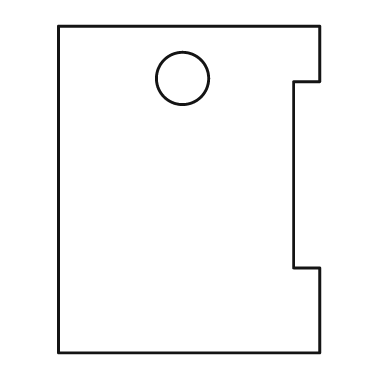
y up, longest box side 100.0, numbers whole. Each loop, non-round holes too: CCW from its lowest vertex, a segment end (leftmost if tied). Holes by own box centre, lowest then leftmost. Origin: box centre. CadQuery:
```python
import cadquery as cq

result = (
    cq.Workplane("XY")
    .moveTo(-40.0, -50.0)
    .lineTo(40.0, -50.0)
    .lineTo(40.0, -24.0)
    .lineTo(32.0, -24.0)
    .lineTo(32.0, 33.0)
    .lineTo(40.0, 33.0)
    .lineTo(40.0, 50.0)
    .lineTo(-40.0, 50.0)
    .close()
    .moveTo(-2.0, 34.0)
    .circle(8.0)
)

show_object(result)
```